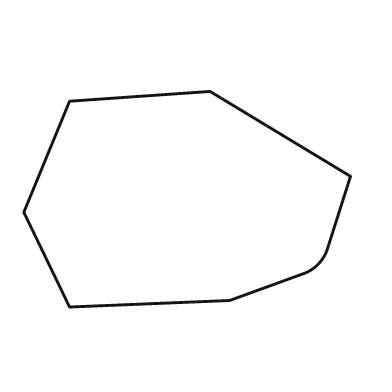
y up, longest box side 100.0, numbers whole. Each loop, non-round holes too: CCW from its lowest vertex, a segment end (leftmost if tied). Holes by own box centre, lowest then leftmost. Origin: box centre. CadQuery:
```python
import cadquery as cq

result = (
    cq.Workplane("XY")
    .moveTo(-36.0, -33.0)
    .lineTo(13.0, -31.0)
    .lineTo(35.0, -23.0)
    .threePointArc((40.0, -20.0), (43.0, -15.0))
    .lineTo(50.0, 7.0)
    .lineTo(7.0, 33.0)
    .lineTo(-36.0, 30.0)
    .lineTo(-50.0, -4.0)
    .close()
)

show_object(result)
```